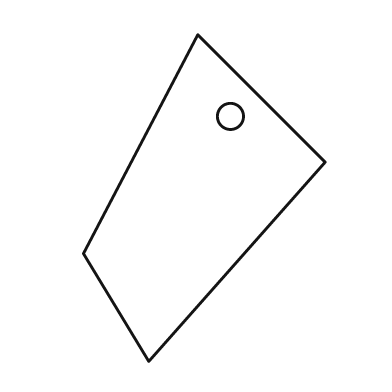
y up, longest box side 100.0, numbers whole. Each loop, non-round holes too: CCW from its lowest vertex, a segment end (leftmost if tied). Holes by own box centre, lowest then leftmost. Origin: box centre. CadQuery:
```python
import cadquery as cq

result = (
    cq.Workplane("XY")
    .moveTo(-17.0, -50.0)
    .lineTo(37.0, 11.0)
    .lineTo(-2.0, 50.0)
    .lineTo(-37.0, -17.0)
    .close()
    .moveTo(8.0, 25.0)
    .circle(4.0)
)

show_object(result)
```